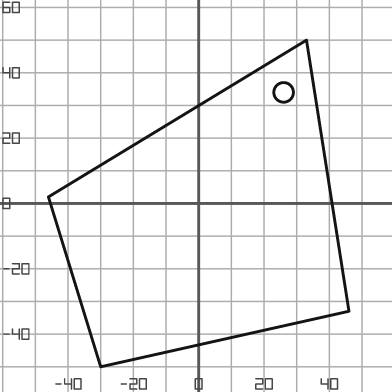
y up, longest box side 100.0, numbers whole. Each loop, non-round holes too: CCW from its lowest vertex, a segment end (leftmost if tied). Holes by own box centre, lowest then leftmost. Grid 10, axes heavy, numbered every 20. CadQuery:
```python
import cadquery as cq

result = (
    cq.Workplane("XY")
    .moveTo(-30.0, -50.0)
    .lineTo(46.0, -33.0)
    .lineTo(33.0, 50.0)
    .lineTo(-46.0, 2.0)
    .close()
    .moveTo(26.0, 34.0)
    .circle(3.0)
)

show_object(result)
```